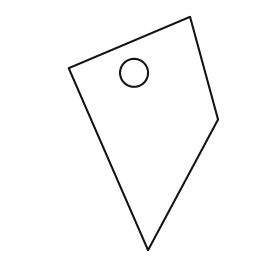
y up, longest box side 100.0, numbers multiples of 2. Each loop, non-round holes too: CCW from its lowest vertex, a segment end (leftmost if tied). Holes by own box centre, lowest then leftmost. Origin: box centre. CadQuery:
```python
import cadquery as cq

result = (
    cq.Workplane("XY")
    .moveTo(2.0, -50.0)
    .lineTo(32.0, 6.0)
    .lineTo(20.0, 50.0)
    .lineTo(-32.0, 28.0)
    .close()
    .moveTo(-4.0, 26.0)
    .circle(6.0)
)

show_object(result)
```